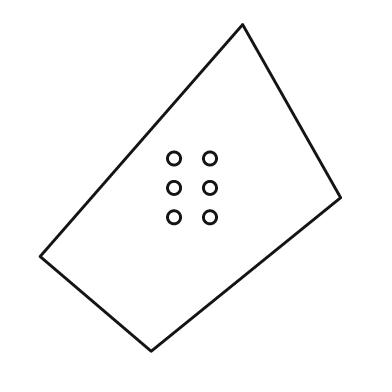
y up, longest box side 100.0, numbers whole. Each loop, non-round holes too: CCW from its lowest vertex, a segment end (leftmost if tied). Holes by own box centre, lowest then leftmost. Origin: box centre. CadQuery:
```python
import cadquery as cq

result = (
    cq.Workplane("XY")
    .moveTo(-12.0, -50.0)
    .lineTo(46.0, -3.0)
    .lineTo(16.0, 50.0)
    .lineTo(-46.0, -21.0)
    .close()
    .moveTo(-5.0, -9.0)
    .circle(2.0)
    .moveTo(6.0, -9.0)
    .circle(2.0)
    .moveTo(-5.0, 0.0)
    .circle(2.0)
    .moveTo(6.0, 0.0)
    .circle(2.0)
    .moveTo(-5.0, 9.0)
    .circle(2.0)
    .moveTo(6.0, 9.0)
    .circle(2.0)
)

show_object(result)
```